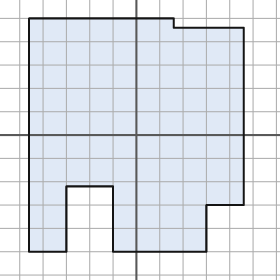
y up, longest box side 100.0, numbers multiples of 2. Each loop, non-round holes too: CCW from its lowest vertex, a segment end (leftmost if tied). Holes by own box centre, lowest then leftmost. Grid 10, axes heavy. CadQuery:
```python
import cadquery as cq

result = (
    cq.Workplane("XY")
    .moveTo(-46.0, -50.0)
    .lineTo(-30.0, -50.0)
    .lineTo(-30.0, -22.0)
    .lineTo(-10.0, -22.0)
    .lineTo(-10.0, -50.0)
    .lineTo(30.0, -50.0)
    .lineTo(30.0, -30.0)
    .lineTo(46.0, -30.0)
    .lineTo(46.0, 46.0)
    .lineTo(16.0, 46.0)
    .lineTo(16.0, 50.0)
    .lineTo(-46.0, 50.0)
    .close()
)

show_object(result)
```